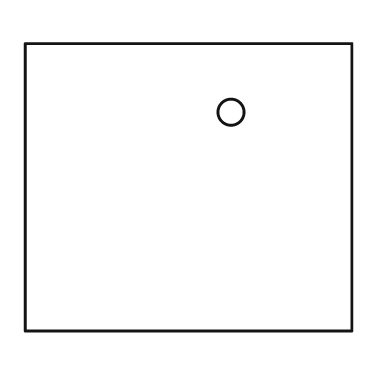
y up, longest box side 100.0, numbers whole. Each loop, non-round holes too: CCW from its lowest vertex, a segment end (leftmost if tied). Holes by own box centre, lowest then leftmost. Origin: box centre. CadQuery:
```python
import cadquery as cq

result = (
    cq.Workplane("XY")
    .moveTo(-50.0, -44.0)
    .lineTo(50.0, -44.0)
    .lineTo(50.0, 44.0)
    .lineTo(-50.0, 44.0)
    .close()
    .moveTo(13.0, 23.0)
    .circle(4.0)
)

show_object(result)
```